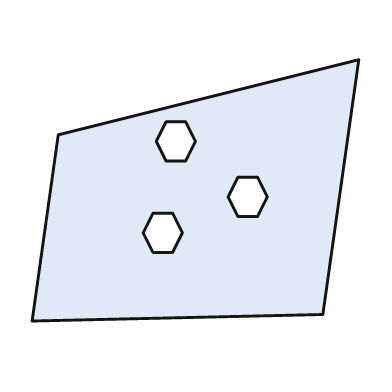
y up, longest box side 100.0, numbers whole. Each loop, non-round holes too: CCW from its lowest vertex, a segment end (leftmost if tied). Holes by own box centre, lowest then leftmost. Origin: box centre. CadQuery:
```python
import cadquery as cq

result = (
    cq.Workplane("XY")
    .moveTo(-50.0, -40.0)
    .lineTo(39.0, -38.0)
    .lineTo(50.0, 40.0)
    .lineTo(-42.0, 17.0)
    .close()
    .moveTo(-13.0, -19.0)
    .lineTo(-7.0, -19.0)
    .lineTo(-4.0, -13.0)
    .lineTo(-7.0, -7.0)
    .lineTo(-13.0, -7.0)
    .lineTo(-16.0, -13.0)
    .close()
    .moveTo(13.0, -8.0)
    .lineTo(19.0, -8.0)
    .lineTo(22.0, -2.0)
    .lineTo(19.0, 4.0)
    .lineTo(13.0, 4.0)
    .lineTo(10.0, -2.0)
    .close()
    .moveTo(-9.0, 9.0)
    .lineTo(-3.0, 9.0)
    .lineTo(0.0, 15.0)
    .lineTo(-3.0, 21.0)
    .lineTo(-9.0, 21.0)
    .lineTo(-12.0, 15.0)
    .close()
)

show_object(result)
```